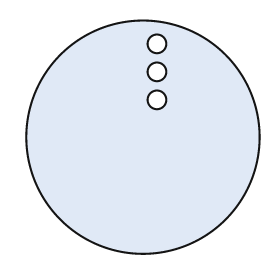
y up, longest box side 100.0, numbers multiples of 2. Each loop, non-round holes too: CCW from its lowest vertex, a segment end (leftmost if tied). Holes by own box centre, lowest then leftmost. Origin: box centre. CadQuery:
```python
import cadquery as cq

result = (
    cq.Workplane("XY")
    .moveTo(0.0, 0.0)
    .circle(50.0)
    .moveTo(6.0, 16.0)
    .circle(4.0)
    .moveTo(6.0, 28.0)
    .circle(4.0)
    .moveTo(6.0, 40.0)
    .circle(4.0)
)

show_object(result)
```